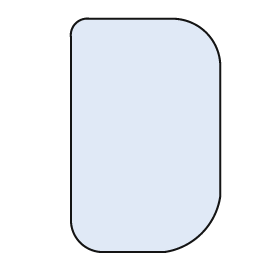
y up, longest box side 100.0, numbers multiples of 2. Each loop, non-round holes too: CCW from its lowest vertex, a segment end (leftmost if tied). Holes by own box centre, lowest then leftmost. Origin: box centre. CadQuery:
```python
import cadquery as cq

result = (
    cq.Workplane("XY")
    .moveTo(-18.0, -50.0)
    .lineTo(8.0, -50.0)
    .threePointArc((24.0, -42.0), (32.0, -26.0))
    .lineTo(32.0, 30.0)
    .threePointArc((26.0, 44.0), (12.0, 50.0))
    .lineTo(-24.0, 50.0)
    .threePointArc((-30.0, 48.0), (-32.0, 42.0))
    .lineTo(-32.0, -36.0)
    .threePointArc((-28.0, -46.0), (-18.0, -50.0))
    .close()
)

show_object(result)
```